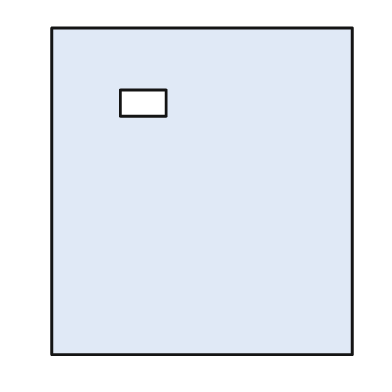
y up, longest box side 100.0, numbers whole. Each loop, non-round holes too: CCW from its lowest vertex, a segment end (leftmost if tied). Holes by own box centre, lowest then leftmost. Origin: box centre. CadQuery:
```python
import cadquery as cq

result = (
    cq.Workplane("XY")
    .moveTo(-46.0, -50.0)
    .lineTo(46.0, -50.0)
    .lineTo(46.0, 50.0)
    .lineTo(-46.0, 50.0)
    .close()
    .moveTo(-25.0, 23.0)
    .lineTo(-11.0, 23.0)
    .lineTo(-11.0, 31.0)
    .lineTo(-25.0, 31.0)
    .close()
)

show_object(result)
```